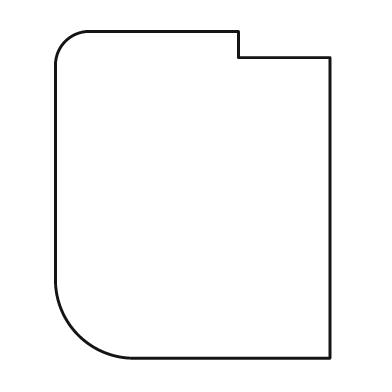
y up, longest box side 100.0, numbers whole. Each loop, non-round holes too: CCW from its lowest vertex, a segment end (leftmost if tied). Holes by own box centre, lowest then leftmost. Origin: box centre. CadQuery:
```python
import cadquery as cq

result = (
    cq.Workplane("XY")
    .moveTo(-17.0, -50.0)
    .lineTo(42.0, -50.0)
    .lineTo(42.0, 42.0)
    .lineTo(14.0, 42.0)
    .lineTo(14.0, 50.0)
    .lineTo(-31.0, 50.0)
    .threePointArc((-39.0, 47.0), (-42.0, 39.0))
    .lineTo(-42.0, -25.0)
    .threePointArc((-35.0, -43.0), (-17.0, -50.0))
    .close()
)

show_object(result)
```